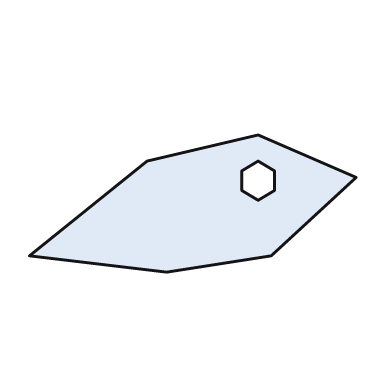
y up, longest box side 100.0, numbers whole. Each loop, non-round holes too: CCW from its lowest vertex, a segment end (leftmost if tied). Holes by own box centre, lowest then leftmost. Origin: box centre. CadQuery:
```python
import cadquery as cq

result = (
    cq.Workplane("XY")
    .moveTo(-8.0, -21.0)
    .lineTo(24.0, -16.0)
    .lineTo(50.0, 8.0)
    .lineTo(20.0, 21.0)
    .lineTo(-14.0, 13.0)
    .lineTo(-50.0, -16.0)
    .close()
    .moveTo(20.0, 1.0)
    .lineTo(25.0, 4.0)
    .lineTo(25.0, 10.0)
    .lineTo(20.0, 13.0)
    .lineTo(15.0, 10.0)
    .lineTo(15.0, 4.0)
    .close()
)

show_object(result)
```